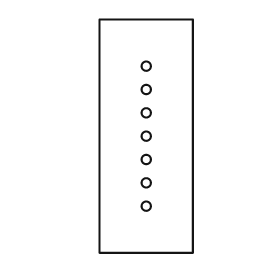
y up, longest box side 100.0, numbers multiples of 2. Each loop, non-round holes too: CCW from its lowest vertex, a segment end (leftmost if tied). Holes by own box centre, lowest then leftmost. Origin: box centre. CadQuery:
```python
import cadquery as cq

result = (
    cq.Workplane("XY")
    .moveTo(-20.0, -50.0)
    .lineTo(20.0, -50.0)
    .lineTo(20.0, 50.0)
    .lineTo(-20.0, 50.0)
    .close()
    .moveTo(0.0, -30.0)
    .circle(2.0)
    .moveTo(0.0, -20.0)
    .circle(2.0)
    .moveTo(0.0, -10.0)
    .circle(2.0)
    .moveTo(0.0, 0.0)
    .circle(2.0)
    .moveTo(0.0, 10.0)
    .circle(2.0)
    .moveTo(0.0, 20.0)
    .circle(2.0)
    .moveTo(0.0, 30.0)
    .circle(2.0)
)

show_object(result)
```